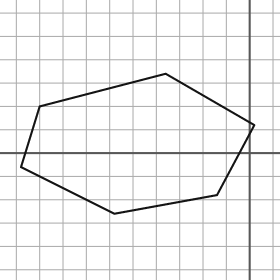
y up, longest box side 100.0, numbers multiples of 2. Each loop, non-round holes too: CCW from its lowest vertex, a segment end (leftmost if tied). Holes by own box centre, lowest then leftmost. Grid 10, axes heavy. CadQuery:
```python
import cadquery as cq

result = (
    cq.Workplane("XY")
    .moveTo(-58.0, -26.0)
    .lineTo(-14.0, -18.0)
    .lineTo(2.0, 12.0)
    .lineTo(-36.0, 34.0)
    .lineTo(-90.0, 20.0)
    .lineTo(-98.0, -6.0)
    .close()
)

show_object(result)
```